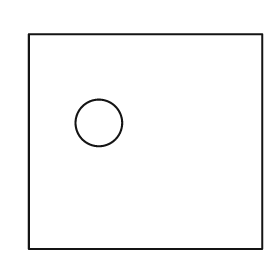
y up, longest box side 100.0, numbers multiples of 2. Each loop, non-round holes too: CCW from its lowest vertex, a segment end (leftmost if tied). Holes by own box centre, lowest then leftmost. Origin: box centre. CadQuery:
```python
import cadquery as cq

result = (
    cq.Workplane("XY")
    .moveTo(-50.0, -46.0)
    .lineTo(50.0, -46.0)
    .lineTo(50.0, 46.0)
    .lineTo(-50.0, 46.0)
    .close()
    .moveTo(-20.0, 8.0)
    .circle(10.0)
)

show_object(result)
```